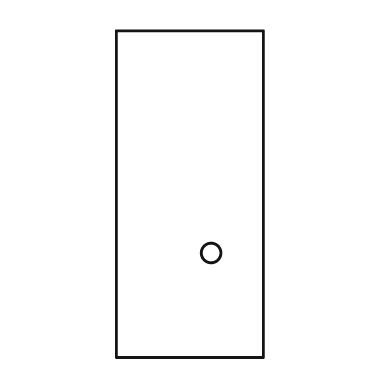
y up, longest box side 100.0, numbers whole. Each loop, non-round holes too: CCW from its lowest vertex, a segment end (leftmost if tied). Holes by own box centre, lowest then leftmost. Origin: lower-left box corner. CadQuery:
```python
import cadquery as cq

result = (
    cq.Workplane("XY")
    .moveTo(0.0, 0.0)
    .lineTo(45.0, 0.0)
    .lineTo(45.0, 100.0)
    .lineTo(0.0, 100.0)
    .close()
    .moveTo(29.0, 32.0)
    .circle(3.0)
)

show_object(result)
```